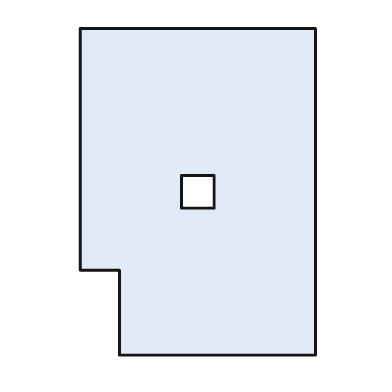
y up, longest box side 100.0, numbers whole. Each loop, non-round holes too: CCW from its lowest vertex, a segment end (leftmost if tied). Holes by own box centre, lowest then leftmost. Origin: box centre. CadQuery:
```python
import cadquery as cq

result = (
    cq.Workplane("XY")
    .moveTo(-24.0, -50.0)
    .lineTo(36.0, -50.0)
    .lineTo(36.0, 50.0)
    .lineTo(-36.0, 50.0)
    .lineTo(-36.0, -24.0)
    .lineTo(-24.0, -24.0)
    .close()
    .moveTo(-5.0, -5.0)
    .lineTo(5.0, -5.0)
    .lineTo(5.0, 5.0)
    .lineTo(-5.0, 5.0)
    .close()
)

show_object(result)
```